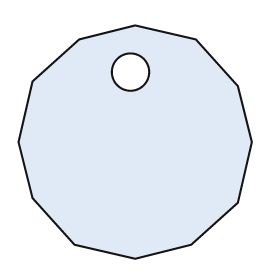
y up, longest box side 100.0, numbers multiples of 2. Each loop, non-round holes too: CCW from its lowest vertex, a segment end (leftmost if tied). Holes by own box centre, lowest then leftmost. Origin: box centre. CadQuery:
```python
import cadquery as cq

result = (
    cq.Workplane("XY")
    .moveTo(0.0, -50.0)
    .lineTo(24.0, -44.0)
    .lineTo(44.0, -26.0)
    .lineTo(50.0, 0.0)
    .lineTo(44.0, 24.0)
    .lineTo(26.0, 44.0)
    .lineTo(0.0, 50.0)
    .lineTo(-24.0, 44.0)
    .lineTo(-44.0, 26.0)
    .lineTo(-50.0, 0.0)
    .lineTo(-44.0, -24.0)
    .lineTo(-26.0, -44.0)
    .close()
    .moveTo(-2.0, 30.0)
    .circle(8.0)
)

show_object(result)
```